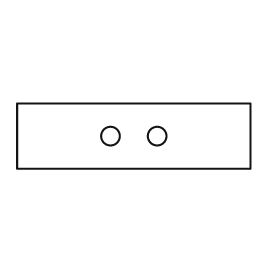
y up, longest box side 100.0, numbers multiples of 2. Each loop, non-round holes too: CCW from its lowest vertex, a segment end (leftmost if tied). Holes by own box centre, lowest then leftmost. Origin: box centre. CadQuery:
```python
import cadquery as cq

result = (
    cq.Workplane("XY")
    .moveTo(-50.0, -14.0)
    .lineTo(50.0, -14.0)
    .lineTo(50.0, 14.0)
    .lineTo(-50.0, 14.0)
    .close()
    .moveTo(-10.0, 0.0)
    .circle(4.0)
    .moveTo(10.0, 0.0)
    .circle(4.0)
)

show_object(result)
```